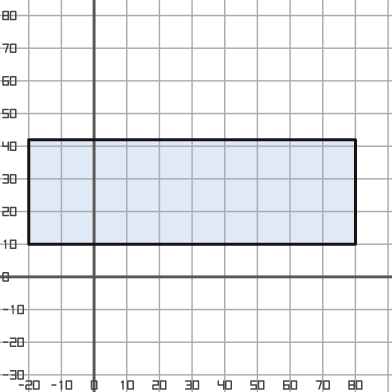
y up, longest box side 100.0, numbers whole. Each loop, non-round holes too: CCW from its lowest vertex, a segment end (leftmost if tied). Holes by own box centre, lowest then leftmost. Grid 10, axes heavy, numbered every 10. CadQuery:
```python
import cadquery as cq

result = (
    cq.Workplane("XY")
    .moveTo(-20.0, 10.0)
    .lineTo(80.0, 10.0)
    .lineTo(80.0, 42.0)
    .lineTo(-20.0, 42.0)
    .close()
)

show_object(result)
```